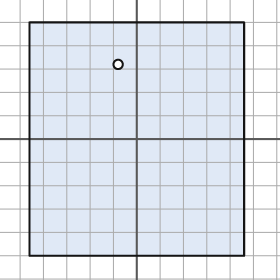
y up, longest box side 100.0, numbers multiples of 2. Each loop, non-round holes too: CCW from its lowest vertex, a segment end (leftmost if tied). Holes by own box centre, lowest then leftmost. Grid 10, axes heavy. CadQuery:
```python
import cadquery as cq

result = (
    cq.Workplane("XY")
    .moveTo(-46.0, -50.0)
    .lineTo(46.0, -50.0)
    .lineTo(46.0, 50.0)
    .lineTo(-46.0, 50.0)
    .close()
    .moveTo(-8.0, 32.0)
    .circle(2.0)
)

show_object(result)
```